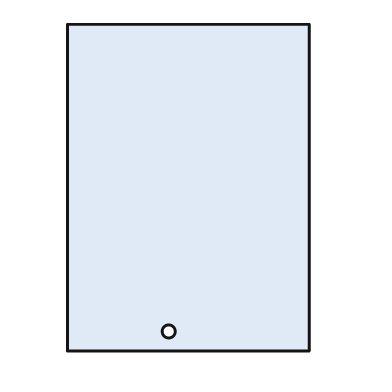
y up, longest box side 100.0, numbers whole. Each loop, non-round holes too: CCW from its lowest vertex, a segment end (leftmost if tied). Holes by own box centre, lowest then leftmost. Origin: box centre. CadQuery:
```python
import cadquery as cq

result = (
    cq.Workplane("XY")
    .moveTo(-37.0, -50.0)
    .lineTo(37.0, -50.0)
    .lineTo(37.0, 50.0)
    .lineTo(-37.0, 50.0)
    .close()
    .moveTo(-6.0, -44.0)
    .circle(2.0)
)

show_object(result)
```